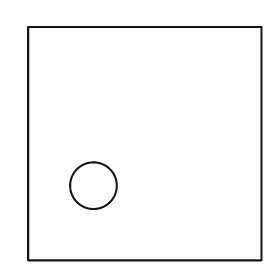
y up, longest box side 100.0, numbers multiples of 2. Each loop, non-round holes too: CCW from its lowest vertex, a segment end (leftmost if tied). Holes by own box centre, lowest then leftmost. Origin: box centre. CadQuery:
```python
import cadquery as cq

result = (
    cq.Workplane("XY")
    .moveTo(-50.0, -50.0)
    .lineTo(50.0, -50.0)
    .lineTo(50.0, 50.0)
    .lineTo(-50.0, 50.0)
    .close()
    .moveTo(-22.0, -18.0)
    .circle(10.0)
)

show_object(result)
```